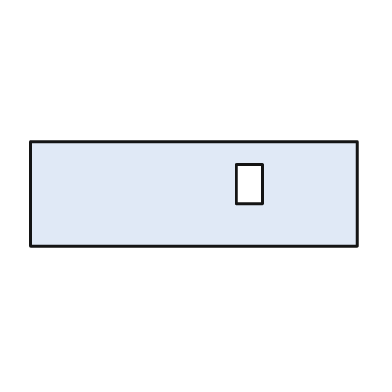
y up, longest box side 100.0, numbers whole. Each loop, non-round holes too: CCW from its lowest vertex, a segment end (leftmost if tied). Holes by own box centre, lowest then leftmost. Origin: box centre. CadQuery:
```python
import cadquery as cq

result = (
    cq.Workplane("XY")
    .moveTo(-50.0, -16.0)
    .lineTo(50.0, -16.0)
    .lineTo(50.0, 16.0)
    .lineTo(-50.0, 16.0)
    .close()
    .moveTo(13.0, -3.0)
    .lineTo(21.0, -3.0)
    .lineTo(21.0, 9.0)
    .lineTo(13.0, 9.0)
    .close()
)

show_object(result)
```